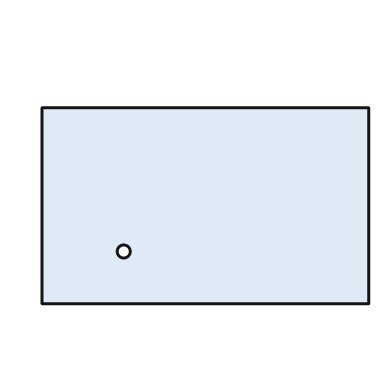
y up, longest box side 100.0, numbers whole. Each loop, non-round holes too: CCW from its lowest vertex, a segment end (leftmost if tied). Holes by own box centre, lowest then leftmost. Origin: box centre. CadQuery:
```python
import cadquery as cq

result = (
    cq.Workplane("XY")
    .moveTo(-50.0, -30.0)
    .lineTo(50.0, -30.0)
    .lineTo(50.0, 30.0)
    .lineTo(-50.0, 30.0)
    .close()
    .moveTo(-25.0, -14.0)
    .circle(2.0)
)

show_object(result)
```